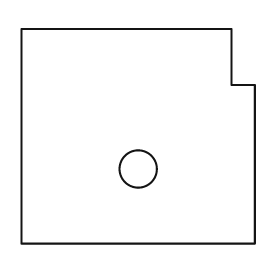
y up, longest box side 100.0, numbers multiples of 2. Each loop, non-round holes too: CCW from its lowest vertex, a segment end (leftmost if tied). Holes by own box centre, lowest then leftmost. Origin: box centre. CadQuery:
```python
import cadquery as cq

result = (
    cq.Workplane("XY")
    .moveTo(-50.0, -46.0)
    .lineTo(50.0, -46.0)
    .lineTo(50.0, 22.0)
    .lineTo(40.0, 22.0)
    .lineTo(40.0, 46.0)
    .lineTo(-50.0, 46.0)
    .close()
    .moveTo(0.0, -14.0)
    .circle(8.0)
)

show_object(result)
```